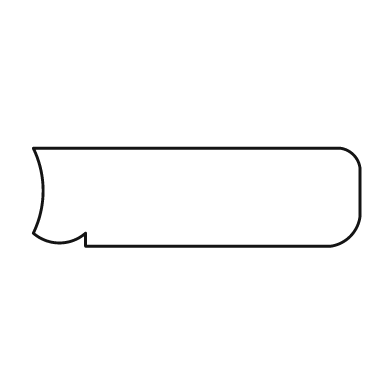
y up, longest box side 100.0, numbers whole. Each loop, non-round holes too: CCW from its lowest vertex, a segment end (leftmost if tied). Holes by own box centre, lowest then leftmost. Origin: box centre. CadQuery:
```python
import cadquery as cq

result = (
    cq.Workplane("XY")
    .moveTo(-34.0, -15.0)
    .lineTo(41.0, -15.0)
    .threePointArc((47.0, -12.0), (50.0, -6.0))
    .lineTo(50.0, 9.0)
    .threePointArc((48.0, 13.0), (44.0, 15.0))
    .lineTo(-50.0, 15.0)
    .threePointArc((-47.0, 2.0), (-50.0, -11.0))
    .threePointArc((-42.0, -14.0), (-34.0, -11.0))
    .close()
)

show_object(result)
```